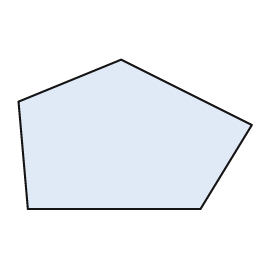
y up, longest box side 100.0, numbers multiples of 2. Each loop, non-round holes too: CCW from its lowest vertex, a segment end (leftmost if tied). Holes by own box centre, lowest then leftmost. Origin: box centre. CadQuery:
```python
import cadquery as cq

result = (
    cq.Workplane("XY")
    .moveTo(-46.0, -32.0)
    .lineTo(28.0, -32.0)
    .lineTo(50.0, 4.0)
    .lineTo(-6.0, 32.0)
    .lineTo(-50.0, 14.0)
    .close()
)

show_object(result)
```